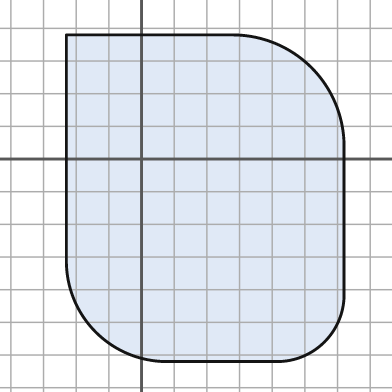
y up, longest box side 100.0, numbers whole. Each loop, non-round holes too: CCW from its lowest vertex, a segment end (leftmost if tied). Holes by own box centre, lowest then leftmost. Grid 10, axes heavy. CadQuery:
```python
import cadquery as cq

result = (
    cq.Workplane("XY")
    .moveTo(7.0, -62.0)
    .lineTo(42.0, -62.0)
    .threePointArc((56.0, -56.0), (62.0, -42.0))
    .lineTo(62.0, 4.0)
    .threePointArc((52.0, 28.0), (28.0, 38.0))
    .lineTo(-23.0, 38.0)
    .lineTo(-23.0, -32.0)
    .threePointArc((-14.0, -53.0), (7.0, -62.0))
    .close()
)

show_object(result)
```